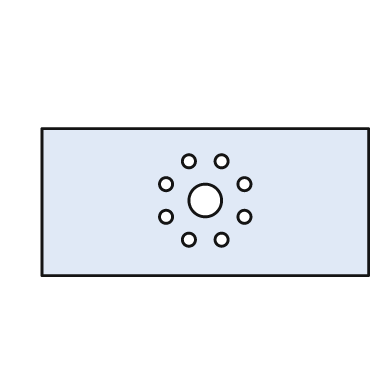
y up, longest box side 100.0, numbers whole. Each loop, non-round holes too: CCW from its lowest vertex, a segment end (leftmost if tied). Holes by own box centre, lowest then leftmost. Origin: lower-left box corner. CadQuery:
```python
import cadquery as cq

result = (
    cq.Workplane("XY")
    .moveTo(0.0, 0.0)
    .lineTo(100.0, 0.0)
    .lineTo(100.0, 45.0)
    .lineTo(0.0, 45.0)
    .close()
    .moveTo(45.0, 11.0)
    .circle(2.0)
    .moveTo(55.0, 11.0)
    .circle(2.0)
    .moveTo(38.0, 18.0)
    .circle(2.0)
    .moveTo(62.0, 18.0)
    .circle(2.0)
    .moveTo(50.0, 23.0)
    .circle(5.0)
    .moveTo(38.0, 28.0)
    .circle(2.0)
    .moveTo(62.0, 28.0)
    .circle(2.0)
    .moveTo(45.0, 35.0)
    .circle(2.0)
    .moveTo(55.0, 35.0)
    .circle(2.0)
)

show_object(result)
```